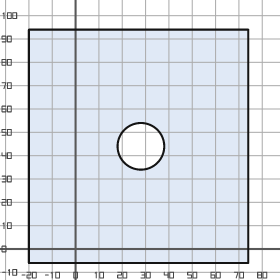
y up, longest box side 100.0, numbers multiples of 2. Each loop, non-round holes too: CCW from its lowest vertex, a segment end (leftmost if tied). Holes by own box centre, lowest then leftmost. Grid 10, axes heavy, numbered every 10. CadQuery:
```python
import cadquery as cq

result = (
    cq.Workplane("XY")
    .moveTo(-20.0, -6.0)
    .lineTo(74.0, -6.0)
    .lineTo(74.0, 94.0)
    .lineTo(-20.0, 94.0)
    .close()
    .moveTo(28.0, 44.0)
    .circle(10.0)
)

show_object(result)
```